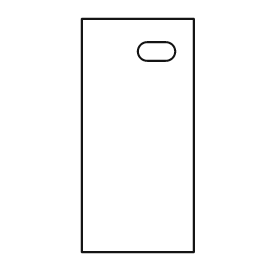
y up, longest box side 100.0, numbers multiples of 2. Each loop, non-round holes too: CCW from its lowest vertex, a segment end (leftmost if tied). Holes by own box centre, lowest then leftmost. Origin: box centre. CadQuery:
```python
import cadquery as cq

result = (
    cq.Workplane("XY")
    .moveTo(-24.0, -50.0)
    .lineTo(24.0, -50.0)
    .lineTo(24.0, 50.0)
    .lineTo(-24.0, 50.0)
    .close()
    .moveTo(4.0, 32.0)
    .lineTo(12.0, 32.0)
    .threePointArc((16.0, 36.0), (12.0, 40.0))
    .lineTo(4.0, 40.0)
    .threePointArc((0.0, 36.0), (4.0, 32.0))
    .close()
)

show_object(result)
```